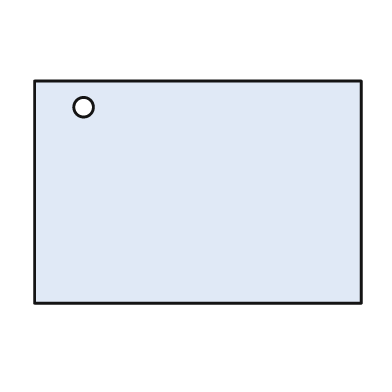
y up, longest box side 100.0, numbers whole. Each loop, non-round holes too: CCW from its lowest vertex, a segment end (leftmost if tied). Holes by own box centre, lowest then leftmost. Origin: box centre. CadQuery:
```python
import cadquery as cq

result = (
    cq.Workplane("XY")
    .moveTo(-50.0, -34.0)
    .lineTo(50.0, -34.0)
    .lineTo(50.0, 34.0)
    .lineTo(-50.0, 34.0)
    .close()
    .moveTo(-35.0, 26.0)
    .circle(3.0)
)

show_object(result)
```